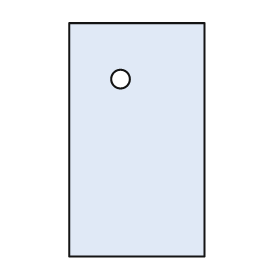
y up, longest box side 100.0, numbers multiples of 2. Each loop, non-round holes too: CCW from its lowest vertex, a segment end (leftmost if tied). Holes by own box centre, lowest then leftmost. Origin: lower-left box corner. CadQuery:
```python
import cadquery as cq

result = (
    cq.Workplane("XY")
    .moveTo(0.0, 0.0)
    .lineTo(58.0, 0.0)
    .lineTo(58.0, 100.0)
    .lineTo(0.0, 100.0)
    .close()
    .moveTo(22.0, 76.0)
    .circle(4.0)
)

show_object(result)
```